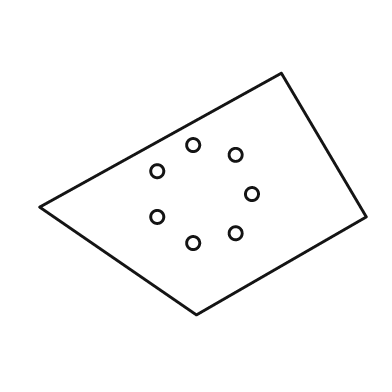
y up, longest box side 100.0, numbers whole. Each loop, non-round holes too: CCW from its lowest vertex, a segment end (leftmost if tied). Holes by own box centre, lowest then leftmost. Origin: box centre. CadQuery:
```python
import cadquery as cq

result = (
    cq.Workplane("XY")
    .moveTo(-2.0, -37.0)
    .lineTo(50.0, -7.0)
    .lineTo(24.0, 37.0)
    .lineTo(-50.0, -4.0)
    .close()
    .moveTo(-3.0, -15.0)
    .circle(2.0)
    .moveTo(10.0, -12.0)
    .circle(2.0)
    .moveTo(-14.0, -7.0)
    .circle(2.0)
    .moveTo(15.0, 0.0)
    .circle(2.0)
    .moveTo(-14.0, 7.0)
    .circle(2.0)
    .moveTo(10.0, 12.0)
    .circle(2.0)
    .moveTo(-3.0, 15.0)
    .circle(2.0)
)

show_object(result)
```